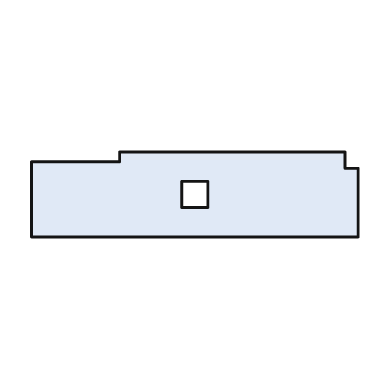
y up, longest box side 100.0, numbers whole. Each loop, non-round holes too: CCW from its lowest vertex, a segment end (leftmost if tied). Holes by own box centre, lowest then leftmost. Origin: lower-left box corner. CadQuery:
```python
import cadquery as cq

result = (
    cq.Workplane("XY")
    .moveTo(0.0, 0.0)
    .lineTo(100.0, 0.0)
    .lineTo(100.0, 21.0)
    .lineTo(96.0, 21.0)
    .lineTo(96.0, 26.0)
    .lineTo(27.0, 26.0)
    .lineTo(27.0, 23.0)
    .lineTo(0.0, 23.0)
    .close()
    .moveTo(46.0, 9.0)
    .lineTo(54.0, 9.0)
    .lineTo(54.0, 17.0)
    .lineTo(46.0, 17.0)
    .close()
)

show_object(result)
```